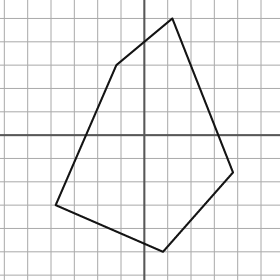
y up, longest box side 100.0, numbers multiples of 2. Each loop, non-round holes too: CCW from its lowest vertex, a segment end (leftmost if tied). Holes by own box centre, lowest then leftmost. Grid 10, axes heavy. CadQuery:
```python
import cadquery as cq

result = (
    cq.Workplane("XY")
    .moveTo(8.0, -50.0)
    .lineTo(38.0, -16.0)
    .lineTo(12.0, 50.0)
    .lineTo(-12.0, 30.0)
    .lineTo(-38.0, -30.0)
    .close()
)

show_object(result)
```